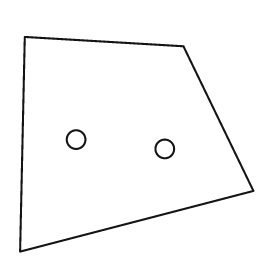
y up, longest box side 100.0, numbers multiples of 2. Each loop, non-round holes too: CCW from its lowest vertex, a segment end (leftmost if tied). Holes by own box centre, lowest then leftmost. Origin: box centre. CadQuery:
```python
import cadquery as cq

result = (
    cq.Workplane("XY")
    .moveTo(-50.0, -46.0)
    .lineTo(50.0, -20.0)
    .lineTo(20.0, 42.0)
    .lineTo(-48.0, 46.0)
    .close()
    .moveTo(12.0, -2.0)
    .circle(4.0)
    .moveTo(-26.0, 2.0)
    .circle(4.0)
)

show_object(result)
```